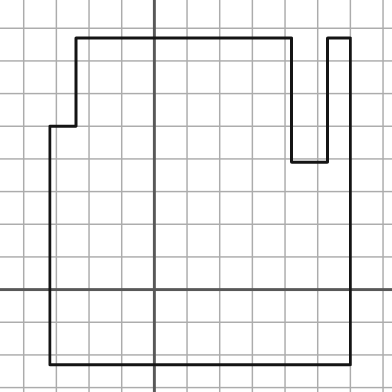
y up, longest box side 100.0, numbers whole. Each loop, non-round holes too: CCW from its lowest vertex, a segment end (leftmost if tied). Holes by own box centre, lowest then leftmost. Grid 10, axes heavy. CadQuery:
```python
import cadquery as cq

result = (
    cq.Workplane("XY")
    .moveTo(-32.0, -23.0)
    .lineTo(60.0, -23.0)
    .lineTo(60.0, 77.0)
    .lineTo(53.0, 77.0)
    .lineTo(53.0, 39.0)
    .lineTo(42.0, 39.0)
    .lineTo(42.0, 77.0)
    .lineTo(-24.0, 77.0)
    .lineTo(-24.0, 50.0)
    .lineTo(-32.0, 50.0)
    .close()
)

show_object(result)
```